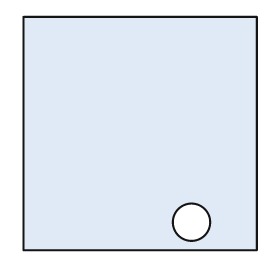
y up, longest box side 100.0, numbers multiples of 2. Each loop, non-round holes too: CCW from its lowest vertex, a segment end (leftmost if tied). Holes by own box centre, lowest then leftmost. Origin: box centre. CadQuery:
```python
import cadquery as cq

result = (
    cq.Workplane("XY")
    .moveTo(-50.0, -50.0)
    .lineTo(50.0, -50.0)
    .lineTo(50.0, 50.0)
    .lineTo(-50.0, 50.0)
    .close()
    .moveTo(22.0, -38.0)
    .circle(8.0)
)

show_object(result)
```